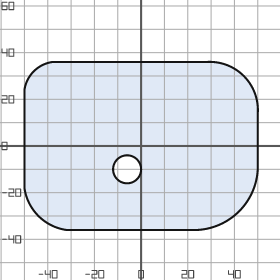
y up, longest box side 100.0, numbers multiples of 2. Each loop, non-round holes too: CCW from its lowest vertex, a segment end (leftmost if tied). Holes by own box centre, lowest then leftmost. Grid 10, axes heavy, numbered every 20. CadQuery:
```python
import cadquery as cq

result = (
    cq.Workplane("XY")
    .moveTo(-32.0, -36.0)
    .lineTo(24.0, -36.0)
    .threePointArc((42.0, -28.0), (50.0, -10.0))
    .lineTo(50.0, 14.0)
    .threePointArc((44.0, 30.0), (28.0, 36.0))
    .lineTo(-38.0, 36.0)
    .threePointArc((-46.0, 32.0), (-50.0, 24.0))
    .lineTo(-50.0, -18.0)
    .threePointArc((-44.0, -30.0), (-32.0, -36.0))
    .close()
    .moveTo(-6.0, -10.0)
    .circle(6.0)
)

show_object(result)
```